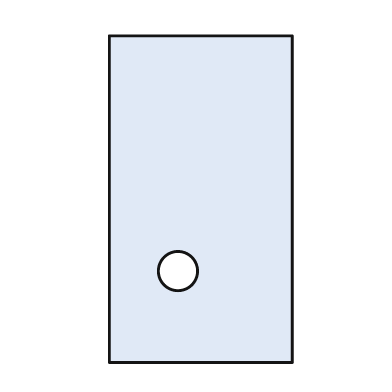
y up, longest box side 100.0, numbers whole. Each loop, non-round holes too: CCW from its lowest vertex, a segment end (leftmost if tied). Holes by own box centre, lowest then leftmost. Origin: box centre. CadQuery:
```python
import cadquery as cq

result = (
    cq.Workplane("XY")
    .moveTo(-28.0, -50.0)
    .lineTo(28.0, -50.0)
    .lineTo(28.0, 50.0)
    .lineTo(-28.0, 50.0)
    .close()
    .moveTo(-7.0, -22.0)
    .circle(6.0)
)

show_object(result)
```